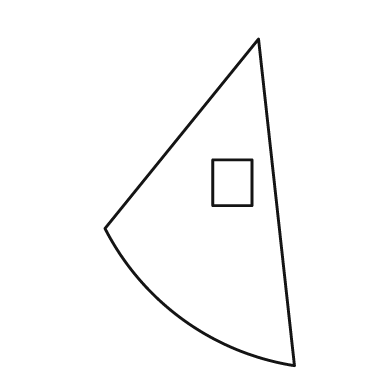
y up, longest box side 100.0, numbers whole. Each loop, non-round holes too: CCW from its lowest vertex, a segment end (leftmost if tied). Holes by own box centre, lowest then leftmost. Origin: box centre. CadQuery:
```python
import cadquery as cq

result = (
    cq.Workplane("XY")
    .moveTo(29.0, -50.0)
    .lineTo(18.0, 50.0)
    .lineTo(-29.0, -8.0)
    .threePointArc((-5.0, -36.0), (29.0, -50.0))
    .close()
    .moveTo(4.0, -1.0)
    .lineTo(16.0, -1.0)
    .lineTo(16.0, 13.0)
    .lineTo(4.0, 13.0)
    .close()
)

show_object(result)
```